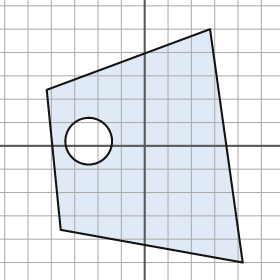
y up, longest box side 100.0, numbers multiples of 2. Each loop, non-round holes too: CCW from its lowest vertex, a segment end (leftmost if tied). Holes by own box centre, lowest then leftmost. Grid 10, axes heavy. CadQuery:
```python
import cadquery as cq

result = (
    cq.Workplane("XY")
    .moveTo(42.0, -50.0)
    .lineTo(28.0, 50.0)
    .lineTo(-42.0, 24.0)
    .lineTo(-36.0, -36.0)
    .close()
    .moveTo(-24.0, 2.0)
    .circle(10.0)
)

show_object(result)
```